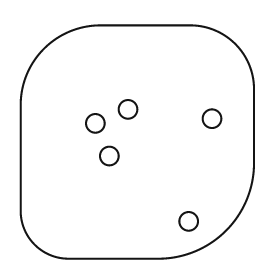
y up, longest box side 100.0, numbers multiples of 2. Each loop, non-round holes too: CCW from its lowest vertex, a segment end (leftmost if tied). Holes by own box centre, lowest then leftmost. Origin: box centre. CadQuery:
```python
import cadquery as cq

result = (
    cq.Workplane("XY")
    .moveTo(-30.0, -50.0)
    .lineTo(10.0, -50.0)
    .threePointArc((38.0, -38.0), (50.0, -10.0))
    .lineTo(50.0, 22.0)
    .threePointArc((42.0, 42.0), (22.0, 50.0))
    .lineTo(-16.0, 50.0)
    .threePointArc((-40.0, 40.0), (-50.0, 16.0))
    .lineTo(-50.0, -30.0)
    .threePointArc((-44.0, -44.0), (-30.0, -50.0))
    .close()
    .moveTo(22.0, -34.0)
    .circle(4.0)
    .moveTo(-12.0, -6.0)
    .circle(4.0)
    .moveTo(-18.0, 8.0)
    .circle(4.0)
    .moveTo(32.0, 10.0)
    .circle(4.0)
    .moveTo(-4.0, 14.0)
    .circle(4.0)
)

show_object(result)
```